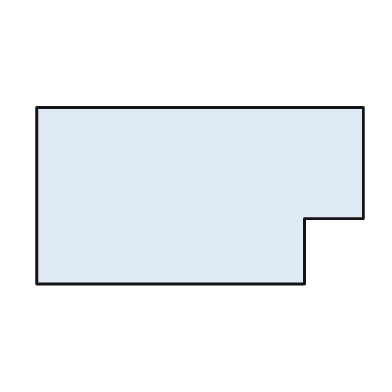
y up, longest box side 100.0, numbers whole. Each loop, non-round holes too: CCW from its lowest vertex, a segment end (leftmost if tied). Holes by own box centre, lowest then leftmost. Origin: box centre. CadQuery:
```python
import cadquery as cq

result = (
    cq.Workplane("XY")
    .moveTo(-50.0, -27.0)
    .lineTo(32.0, -27.0)
    .lineTo(32.0, -7.0)
    .lineTo(50.0, -7.0)
    .lineTo(50.0, 27.0)
    .lineTo(-50.0, 27.0)
    .close()
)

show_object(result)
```